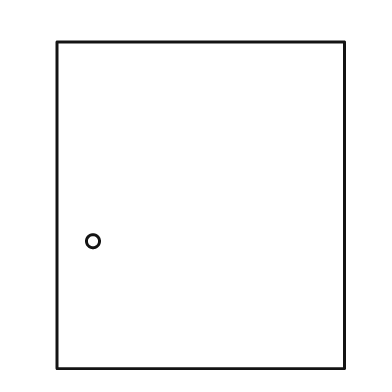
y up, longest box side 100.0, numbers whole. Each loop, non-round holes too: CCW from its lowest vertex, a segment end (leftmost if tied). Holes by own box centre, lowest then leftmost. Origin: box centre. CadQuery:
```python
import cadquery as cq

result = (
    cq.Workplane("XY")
    .moveTo(-44.0, -50.0)
    .lineTo(44.0, -50.0)
    .lineTo(44.0, 50.0)
    .lineTo(-44.0, 50.0)
    .close()
    .moveTo(-33.0, -11.0)
    .circle(2.0)
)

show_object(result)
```